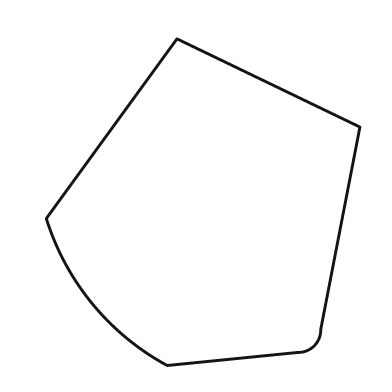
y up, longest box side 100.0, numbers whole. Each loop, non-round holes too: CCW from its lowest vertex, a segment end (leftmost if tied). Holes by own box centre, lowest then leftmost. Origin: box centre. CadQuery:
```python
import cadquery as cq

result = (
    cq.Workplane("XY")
    .moveTo(-11.0, -50.0)
    .lineTo(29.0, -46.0)
    .threePointArc((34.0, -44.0), (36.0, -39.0))
    .lineTo(48.0, 23.0)
    .lineTo(-8.0, 50.0)
    .lineTo(-48.0, -5.0)
    .threePointArc((-34.0, -31.0), (-11.0, -50.0))
    .close()
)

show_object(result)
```